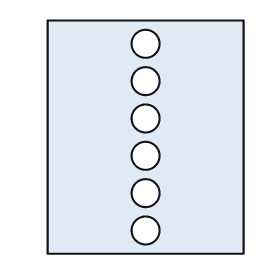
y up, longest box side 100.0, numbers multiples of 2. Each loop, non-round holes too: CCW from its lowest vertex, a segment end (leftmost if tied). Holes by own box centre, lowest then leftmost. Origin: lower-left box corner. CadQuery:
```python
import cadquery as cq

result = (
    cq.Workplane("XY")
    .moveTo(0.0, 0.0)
    .lineTo(84.0, 0.0)
    .lineTo(84.0, 100.0)
    .lineTo(0.0, 100.0)
    .close()
    .moveTo(42.0, 10.0)
    .circle(6.0)
    .moveTo(42.0, 26.0)
    .circle(6.0)
    .moveTo(42.0, 42.0)
    .circle(6.0)
    .moveTo(42.0, 58.0)
    .circle(6.0)
    .moveTo(42.0, 74.0)
    .circle(6.0)
    .moveTo(42.0, 90.0)
    .circle(6.0)
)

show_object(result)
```